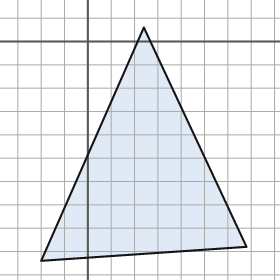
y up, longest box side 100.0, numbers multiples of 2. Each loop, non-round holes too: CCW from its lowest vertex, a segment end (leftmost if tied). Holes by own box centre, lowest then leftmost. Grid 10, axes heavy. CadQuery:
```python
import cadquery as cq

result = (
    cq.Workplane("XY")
    .moveTo(-20.0, -94.0)
    .lineTo(68.0, -88.0)
    .lineTo(24.0, 6.0)
    .close()
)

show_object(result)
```